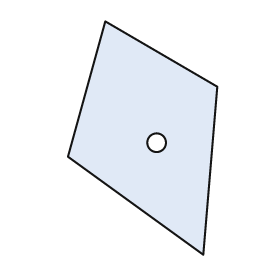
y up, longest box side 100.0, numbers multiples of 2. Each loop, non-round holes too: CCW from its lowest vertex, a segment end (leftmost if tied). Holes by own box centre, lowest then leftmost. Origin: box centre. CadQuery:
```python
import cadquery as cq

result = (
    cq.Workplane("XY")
    .moveTo(26.0, -50.0)
    .lineTo(32.0, 22.0)
    .lineTo(-16.0, 50.0)
    .lineTo(-32.0, -8.0)
    .close()
    .moveTo(6.0, -2.0)
    .circle(4.0)
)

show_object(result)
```